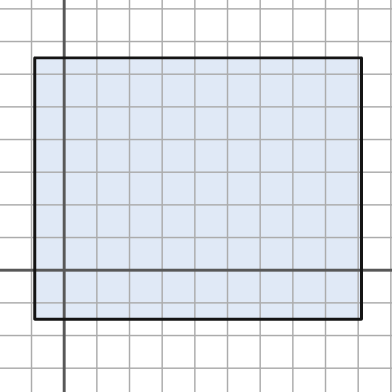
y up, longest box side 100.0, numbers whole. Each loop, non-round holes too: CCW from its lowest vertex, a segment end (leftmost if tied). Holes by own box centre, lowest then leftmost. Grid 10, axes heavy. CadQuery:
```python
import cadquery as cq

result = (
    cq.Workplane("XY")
    .moveTo(-9.0, -15.0)
    .lineTo(91.0, -15.0)
    .lineTo(91.0, 65.0)
    .lineTo(-9.0, 65.0)
    .close()
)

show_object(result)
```